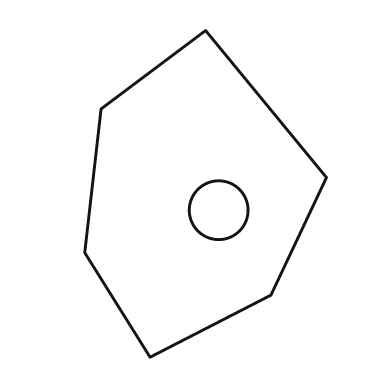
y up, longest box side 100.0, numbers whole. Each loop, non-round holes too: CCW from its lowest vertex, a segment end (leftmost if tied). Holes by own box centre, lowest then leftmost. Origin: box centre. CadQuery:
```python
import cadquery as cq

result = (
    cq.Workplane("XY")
    .moveTo(-17.0, -50.0)
    .lineTo(20.0, -31.0)
    .lineTo(37.0, 5.0)
    .lineTo(0.0, 50.0)
    .lineTo(-32.0, 26.0)
    .lineTo(-37.0, -18.0)
    .close()
    .moveTo(4.0, -5.0)
    .circle(9.0)
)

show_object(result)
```